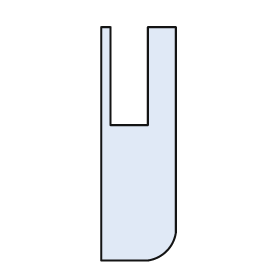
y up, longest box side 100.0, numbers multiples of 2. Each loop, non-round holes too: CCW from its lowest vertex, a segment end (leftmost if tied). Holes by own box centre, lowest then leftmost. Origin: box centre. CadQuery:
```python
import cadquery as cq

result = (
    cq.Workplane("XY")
    .moveTo(-16.0, -50.0)
    .lineTo(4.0, -50.0)
    .threePointArc((12.0, -46.0), (16.0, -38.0))
    .lineTo(16.0, 50.0)
    .lineTo(4.0, 50.0)
    .lineTo(4.0, 8.0)
    .lineTo(-12.0, 8.0)
    .lineTo(-12.0, 50.0)
    .lineTo(-16.0, 50.0)
    .close()
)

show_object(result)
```